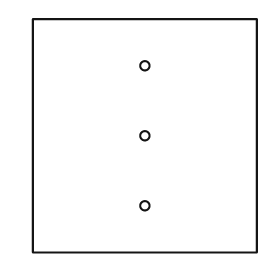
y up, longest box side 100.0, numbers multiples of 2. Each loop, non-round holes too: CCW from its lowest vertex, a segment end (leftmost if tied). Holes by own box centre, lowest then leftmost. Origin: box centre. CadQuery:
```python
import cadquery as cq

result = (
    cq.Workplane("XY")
    .moveTo(-48.0, -50.0)
    .lineTo(48.0, -50.0)
    .lineTo(48.0, 50.0)
    .lineTo(-48.0, 50.0)
    .close()
    .moveTo(0.0, -30.0)
    .circle(2.0)
    .moveTo(0.0, 0.0)
    .circle(2.0)
    .moveTo(0.0, 30.0)
    .circle(2.0)
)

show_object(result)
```